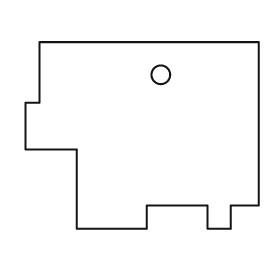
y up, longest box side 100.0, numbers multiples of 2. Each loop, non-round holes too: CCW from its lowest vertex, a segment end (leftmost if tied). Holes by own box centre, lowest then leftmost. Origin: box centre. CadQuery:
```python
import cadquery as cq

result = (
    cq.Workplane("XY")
    .moveTo(-28.0, -40.0)
    .lineTo(2.0, -40.0)
    .lineTo(2.0, -30.0)
    .lineTo(28.0, -30.0)
    .lineTo(28.0, -40.0)
    .lineTo(38.0, -40.0)
    .lineTo(38.0, -30.0)
    .lineTo(50.0, -30.0)
    .lineTo(50.0, 40.0)
    .lineTo(-44.0, 40.0)
    .lineTo(-44.0, 14.0)
    .lineTo(-50.0, 14.0)
    .lineTo(-50.0, -6.0)
    .lineTo(-28.0, -6.0)
    .close()
    .moveTo(8.0, 26.0)
    .circle(4.0)
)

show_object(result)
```